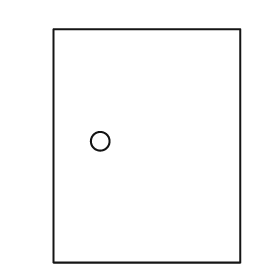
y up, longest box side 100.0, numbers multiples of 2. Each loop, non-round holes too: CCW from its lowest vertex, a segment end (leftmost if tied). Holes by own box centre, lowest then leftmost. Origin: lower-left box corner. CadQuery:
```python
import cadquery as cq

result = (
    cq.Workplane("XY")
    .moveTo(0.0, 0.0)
    .lineTo(80.0, 0.0)
    .lineTo(80.0, 100.0)
    .lineTo(0.0, 100.0)
    .close()
    .moveTo(20.0, 52.0)
    .circle(4.0)
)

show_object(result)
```